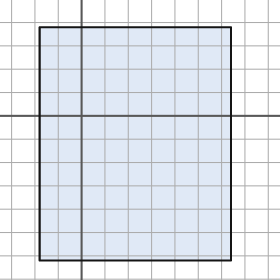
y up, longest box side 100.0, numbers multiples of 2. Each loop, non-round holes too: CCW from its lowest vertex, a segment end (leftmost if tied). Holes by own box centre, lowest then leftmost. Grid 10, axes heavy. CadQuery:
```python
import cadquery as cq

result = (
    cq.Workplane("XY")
    .moveTo(-18.0, -62.0)
    .lineTo(64.0, -62.0)
    .lineTo(64.0, 38.0)
    .lineTo(-18.0, 38.0)
    .close()
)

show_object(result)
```